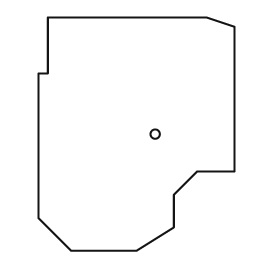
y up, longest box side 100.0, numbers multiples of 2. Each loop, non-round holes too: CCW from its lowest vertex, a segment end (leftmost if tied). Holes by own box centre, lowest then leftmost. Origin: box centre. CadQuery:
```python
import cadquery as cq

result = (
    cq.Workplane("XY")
    .moveTo(-28.0, -50.0)
    .lineTo(0.0, -50.0)
    .lineTo(16.0, -40.0)
    .lineTo(16.0, -26.0)
    .lineTo(26.0, -16.0)
    .lineTo(42.0, -16.0)
    .lineTo(42.0, 46.0)
    .lineTo(30.0, 50.0)
    .lineTo(-38.0, 50.0)
    .lineTo(-38.0, 26.0)
    .lineTo(-42.0, 26.0)
    .lineTo(-42.0, -36.0)
    .close()
    .moveTo(8.0, 0.0)
    .circle(2.0)
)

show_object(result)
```